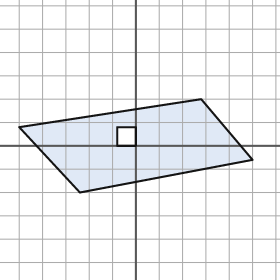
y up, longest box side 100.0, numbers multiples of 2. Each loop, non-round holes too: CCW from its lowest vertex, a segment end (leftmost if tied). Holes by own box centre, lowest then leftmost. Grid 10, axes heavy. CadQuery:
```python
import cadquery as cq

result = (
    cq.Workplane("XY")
    .moveTo(-24.0, -20.0)
    .lineTo(50.0, -6.0)
    .lineTo(28.0, 20.0)
    .lineTo(-50.0, 8.0)
    .close()
    .moveTo(-8.0, 0.0)
    .lineTo(0.0, 0.0)
    .lineTo(0.0, 8.0)
    .lineTo(-8.0, 8.0)
    .close()
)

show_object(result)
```